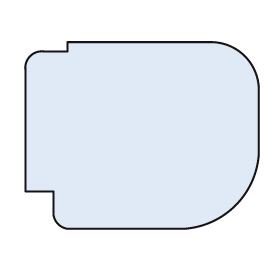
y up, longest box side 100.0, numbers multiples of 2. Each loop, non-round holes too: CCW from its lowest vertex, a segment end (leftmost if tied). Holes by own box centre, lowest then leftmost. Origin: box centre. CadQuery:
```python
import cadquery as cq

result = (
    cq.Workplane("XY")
    .moveTo(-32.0, -40.0)
    .lineTo(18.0, -40.0)
    .threePointArc((40.0, -30.0), (50.0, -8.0))
    .lineTo(50.0, 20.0)
    .threePointArc((44.0, 34.0), (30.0, 40.0))
    .lineTo(-32.0, 40.0)
    .lineTo(-32.0, 36.0)
    .lineTo(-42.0, 36.0)
    .threePointArc((-48.0, 34.0), (-50.0, 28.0))
    .lineTo(-50.0, -24.0)
    .lineTo(-38.0, -24.0)
    .lineTo(-38.0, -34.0)
    .threePointArc((-36.0, -38.0), (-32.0, -40.0))
    .close()
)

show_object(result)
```